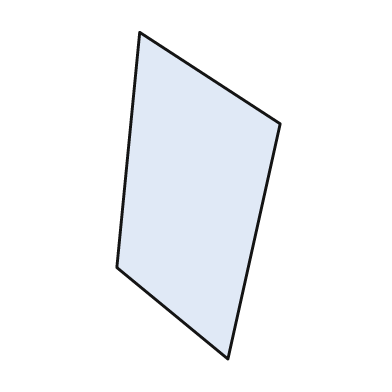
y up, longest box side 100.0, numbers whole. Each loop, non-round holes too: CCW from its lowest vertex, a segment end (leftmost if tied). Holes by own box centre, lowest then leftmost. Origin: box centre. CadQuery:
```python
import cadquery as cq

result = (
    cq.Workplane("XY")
    .moveTo(9.0, -50.0)
    .lineTo(25.0, 22.0)
    .lineTo(-18.0, 50.0)
    .lineTo(-25.0, -22.0)
    .close()
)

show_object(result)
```